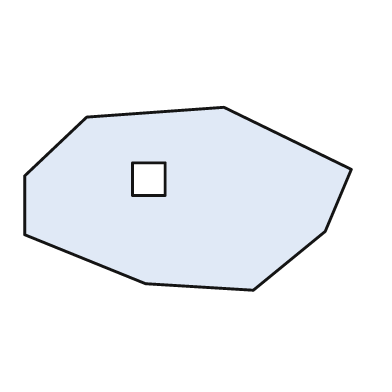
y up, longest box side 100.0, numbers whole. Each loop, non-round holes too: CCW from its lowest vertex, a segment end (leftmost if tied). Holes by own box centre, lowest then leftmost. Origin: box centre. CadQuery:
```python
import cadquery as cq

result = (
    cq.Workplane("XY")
    .moveTo(20.0, -28.0)
    .lineTo(42.0, -10.0)
    .lineTo(50.0, 9.0)
    .lineTo(11.0, 28.0)
    .lineTo(-31.0, 25.0)
    .lineTo(-50.0, 7.0)
    .lineTo(-50.0, -11.0)
    .lineTo(-13.0, -26.0)
    .close()
    .moveTo(-17.0, 1.0)
    .lineTo(-7.0, 1.0)
    .lineTo(-7.0, 11.0)
    .lineTo(-17.0, 11.0)
    .close()
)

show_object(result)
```